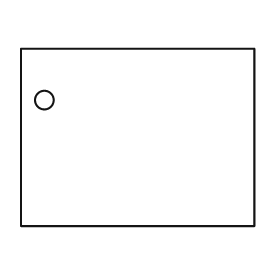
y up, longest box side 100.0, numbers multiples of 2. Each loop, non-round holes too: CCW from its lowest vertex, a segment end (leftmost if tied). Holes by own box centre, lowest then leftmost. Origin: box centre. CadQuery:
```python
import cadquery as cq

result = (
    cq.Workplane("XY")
    .moveTo(-50.0, -38.0)
    .lineTo(50.0, -38.0)
    .lineTo(50.0, 38.0)
    .lineTo(-50.0, 38.0)
    .close()
    .moveTo(-40.0, 16.0)
    .circle(4.0)
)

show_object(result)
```